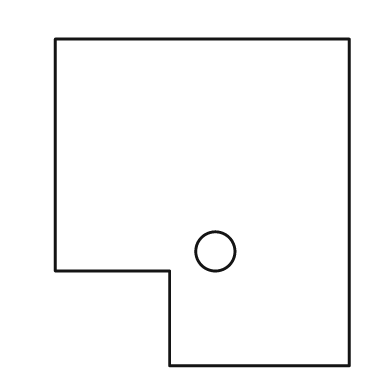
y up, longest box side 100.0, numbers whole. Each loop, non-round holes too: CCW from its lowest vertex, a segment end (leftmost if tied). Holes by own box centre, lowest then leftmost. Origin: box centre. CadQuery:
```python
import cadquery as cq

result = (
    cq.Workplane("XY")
    .moveTo(-10.0, -50.0)
    .lineTo(45.0, -50.0)
    .lineTo(45.0, 50.0)
    .lineTo(-45.0, 50.0)
    .lineTo(-45.0, -21.0)
    .lineTo(-10.0, -21.0)
    .close()
    .moveTo(4.0, -15.0)
    .circle(6.0)
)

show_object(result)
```